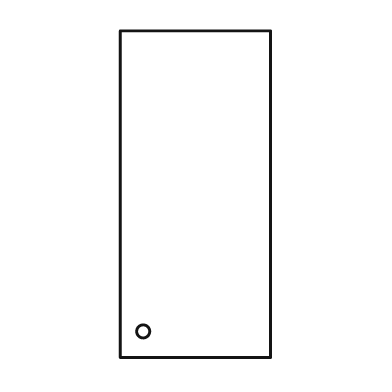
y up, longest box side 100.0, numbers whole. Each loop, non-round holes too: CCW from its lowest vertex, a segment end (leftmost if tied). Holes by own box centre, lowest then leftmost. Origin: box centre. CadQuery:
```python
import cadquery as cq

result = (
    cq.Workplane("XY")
    .moveTo(-23.0, -50.0)
    .lineTo(23.0, -50.0)
    .lineTo(23.0, 50.0)
    .lineTo(-23.0, 50.0)
    .close()
    .moveTo(-16.0, -42.0)
    .circle(2.0)
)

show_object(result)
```